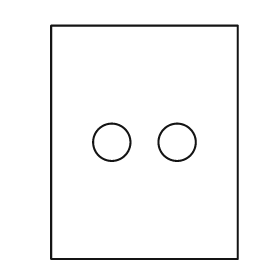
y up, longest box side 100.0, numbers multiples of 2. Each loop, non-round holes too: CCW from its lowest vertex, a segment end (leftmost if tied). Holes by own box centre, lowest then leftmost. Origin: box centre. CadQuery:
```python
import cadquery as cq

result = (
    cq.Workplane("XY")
    .moveTo(-40.0, -50.0)
    .lineTo(40.0, -50.0)
    .lineTo(40.0, 50.0)
    .lineTo(-40.0, 50.0)
    .close()
    .moveTo(-14.0, 0.0)
    .circle(8.0)
    .moveTo(14.0, 0.0)
    .circle(8.0)
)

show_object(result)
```